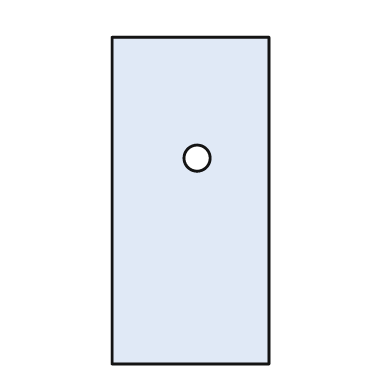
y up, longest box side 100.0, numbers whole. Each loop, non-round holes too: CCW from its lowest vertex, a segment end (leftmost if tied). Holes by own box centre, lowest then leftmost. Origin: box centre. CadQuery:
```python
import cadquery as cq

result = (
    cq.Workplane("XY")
    .moveTo(-24.0, -50.0)
    .lineTo(24.0, -50.0)
    .lineTo(24.0, 50.0)
    .lineTo(-24.0, 50.0)
    .close()
    .moveTo(2.0, 13.0)
    .circle(4.0)
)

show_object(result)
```